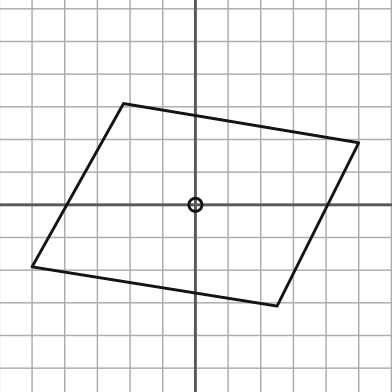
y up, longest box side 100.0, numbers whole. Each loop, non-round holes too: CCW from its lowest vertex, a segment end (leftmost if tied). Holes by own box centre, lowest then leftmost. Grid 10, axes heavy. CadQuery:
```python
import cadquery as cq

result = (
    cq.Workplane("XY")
    .moveTo(25.0, -31.0)
    .lineTo(50.0, 19.0)
    .lineTo(-22.0, 31.0)
    .lineTo(-50.0, -19.0)
    .close()
    .moveTo(0.0, 0.0)
    .circle(2.0)
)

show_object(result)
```